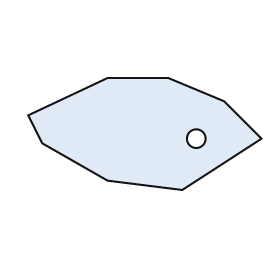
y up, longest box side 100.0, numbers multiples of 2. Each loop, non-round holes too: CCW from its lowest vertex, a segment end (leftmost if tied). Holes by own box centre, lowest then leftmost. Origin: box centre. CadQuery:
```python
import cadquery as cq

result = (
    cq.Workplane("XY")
    .moveTo(16.0, -24.0)
    .lineTo(50.0, -2.0)
    .lineTo(34.0, 14.0)
    .lineTo(10.0, 24.0)
    .lineTo(-16.0, 24.0)
    .lineTo(-50.0, 8.0)
    .lineTo(-44.0, -4.0)
    .lineTo(-16.0, -20.0)
    .close()
    .moveTo(22.0, -2.0)
    .circle(4.0)
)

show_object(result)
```